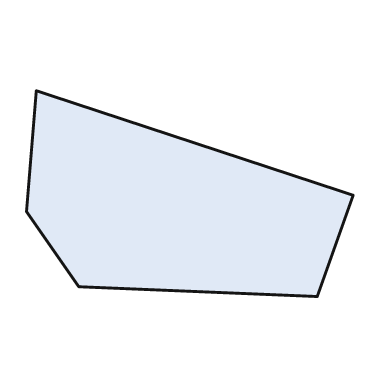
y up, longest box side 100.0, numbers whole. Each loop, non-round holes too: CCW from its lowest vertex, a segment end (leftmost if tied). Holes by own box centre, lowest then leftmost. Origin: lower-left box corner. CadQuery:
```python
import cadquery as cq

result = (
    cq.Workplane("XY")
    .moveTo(89.0, 0.0)
    .lineTo(100.0, 31.0)
    .lineTo(3.0, 63.0)
    .lineTo(0.0, 26.0)
    .lineTo(16.0, 3.0)
    .close()
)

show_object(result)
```